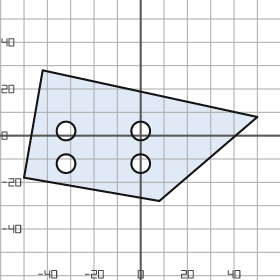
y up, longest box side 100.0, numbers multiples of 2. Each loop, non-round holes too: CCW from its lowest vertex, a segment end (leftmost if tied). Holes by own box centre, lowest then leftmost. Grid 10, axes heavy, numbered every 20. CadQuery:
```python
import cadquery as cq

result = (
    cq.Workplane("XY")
    .moveTo(8.0, -28.0)
    .lineTo(50.0, 8.0)
    .lineTo(-42.0, 28.0)
    .lineTo(-50.0, -18.0)
    .close()
    .moveTo(-32.0, -12.0)
    .circle(4.0)
    .moveTo(0.0, -12.0)
    .circle(4.0)
    .moveTo(-32.0, 2.0)
    .circle(4.0)
    .moveTo(0.0, 2.0)
    .circle(4.0)
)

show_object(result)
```